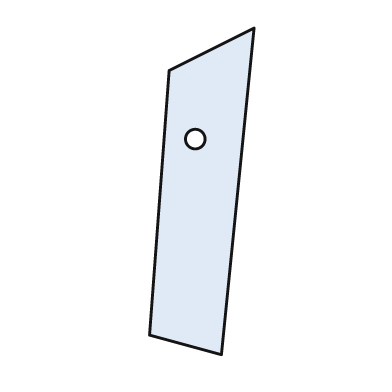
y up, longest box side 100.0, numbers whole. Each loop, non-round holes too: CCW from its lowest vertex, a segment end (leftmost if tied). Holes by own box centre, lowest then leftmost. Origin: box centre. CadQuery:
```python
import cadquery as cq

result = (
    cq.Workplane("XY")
    .moveTo(6.0, -50.0)
    .lineTo(16.0, 50.0)
    .lineTo(-10.0, 37.0)
    .lineTo(-16.0, -44.0)
    .close()
    .moveTo(-2.0, 16.0)
    .circle(3.0)
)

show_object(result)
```